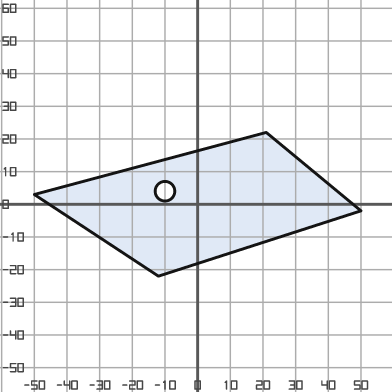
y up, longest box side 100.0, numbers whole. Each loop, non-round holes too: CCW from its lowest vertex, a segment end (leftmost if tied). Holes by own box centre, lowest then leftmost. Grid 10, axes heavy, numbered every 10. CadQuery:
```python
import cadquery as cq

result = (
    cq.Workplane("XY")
    .moveTo(-12.0, -22.0)
    .lineTo(50.0, -2.0)
    .lineTo(21.0, 22.0)
    .lineTo(-50.0, 3.0)
    .close()
    .moveTo(-10.0, 4.0)
    .circle(3.0)
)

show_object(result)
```